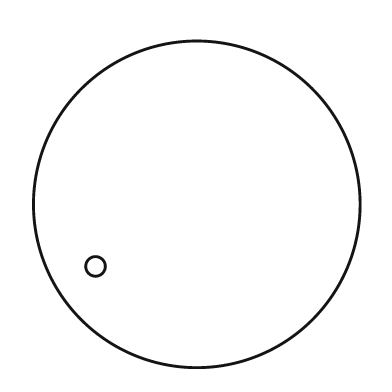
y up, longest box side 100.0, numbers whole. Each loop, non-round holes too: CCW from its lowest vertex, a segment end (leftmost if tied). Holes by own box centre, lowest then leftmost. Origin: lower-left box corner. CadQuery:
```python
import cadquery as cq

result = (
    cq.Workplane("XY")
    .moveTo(50.0, 50.0)
    .circle(50.0)
    .moveTo(19.0, 31.0)
    .circle(3.0)
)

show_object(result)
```